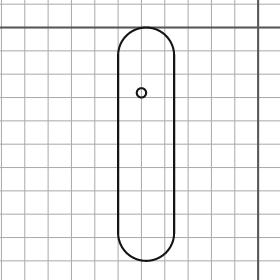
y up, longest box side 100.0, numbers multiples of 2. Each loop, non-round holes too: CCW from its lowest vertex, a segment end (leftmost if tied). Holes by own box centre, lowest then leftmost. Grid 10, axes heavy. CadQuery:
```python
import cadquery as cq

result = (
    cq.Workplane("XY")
    .moveTo(-60.0, -88.0)
    .threePointArc((-48.0, -100.0), (-36.0, -88.0))
    .lineTo(-36.0, -12.0)
    .threePointArc((-48.0, 0.0), (-60.0, -12.0))
    .close()
    .moveTo(-50.0, -28.0)
    .circle(2.0)
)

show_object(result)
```